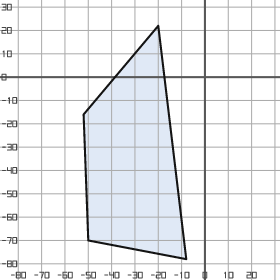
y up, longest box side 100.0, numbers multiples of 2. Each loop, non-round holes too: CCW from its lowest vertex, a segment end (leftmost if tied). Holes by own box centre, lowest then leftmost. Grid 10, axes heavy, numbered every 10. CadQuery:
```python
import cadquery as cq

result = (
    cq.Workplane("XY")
    .moveTo(-8.0, -78.0)
    .lineTo(-20.0, 22.0)
    .lineTo(-52.0, -16.0)
    .lineTo(-50.0, -70.0)
    .close()
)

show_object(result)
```